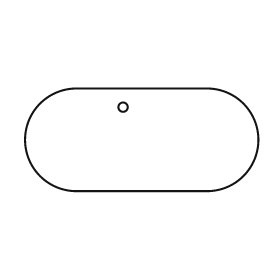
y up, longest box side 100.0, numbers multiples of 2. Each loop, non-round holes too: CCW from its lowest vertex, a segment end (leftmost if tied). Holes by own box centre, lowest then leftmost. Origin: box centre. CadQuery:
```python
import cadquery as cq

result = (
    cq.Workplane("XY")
    .moveTo(-28.0, -22.0)
    .lineTo(28.0, -22.0)
    .threePointArc((50.0, 0.0), (28.0, 22.0))
    .lineTo(-28.0, 22.0)
    .threePointArc((-50.0, 0.0), (-28.0, -22.0))
    .close()
    .moveTo(-8.0, 14.0)
    .circle(2.0)
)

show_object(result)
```